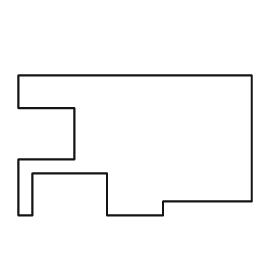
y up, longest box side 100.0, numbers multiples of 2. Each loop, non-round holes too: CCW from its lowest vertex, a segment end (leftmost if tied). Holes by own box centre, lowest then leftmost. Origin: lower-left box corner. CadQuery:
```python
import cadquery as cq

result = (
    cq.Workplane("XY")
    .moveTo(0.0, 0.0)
    .lineTo(6.0, 0.0)
    .lineTo(6.0, 18.0)
    .lineTo(38.0, 18.0)
    .lineTo(38.0, 0.0)
    .lineTo(62.0, 0.0)
    .lineTo(62.0, 6.0)
    .lineTo(100.0, 6.0)
    .lineTo(100.0, 60.0)
    .lineTo(0.0, 60.0)
    .lineTo(0.0, 46.0)
    .lineTo(24.0, 46.0)
    .lineTo(24.0, 24.0)
    .lineTo(0.0, 24.0)
    .close()
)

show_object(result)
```